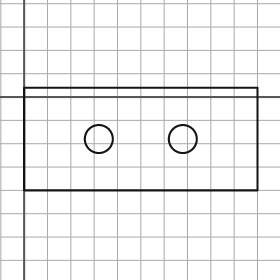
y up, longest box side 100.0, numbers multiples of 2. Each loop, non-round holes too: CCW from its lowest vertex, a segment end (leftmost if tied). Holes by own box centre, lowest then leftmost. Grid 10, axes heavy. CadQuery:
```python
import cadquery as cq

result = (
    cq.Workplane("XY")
    .moveTo(0.0, -40.0)
    .lineTo(100.0, -40.0)
    .lineTo(100.0, 4.0)
    .lineTo(0.0, 4.0)
    .close()
    .moveTo(32.0, -18.0)
    .circle(6.0)
    .moveTo(68.0, -18.0)
    .circle(6.0)
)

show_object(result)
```